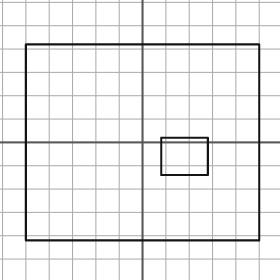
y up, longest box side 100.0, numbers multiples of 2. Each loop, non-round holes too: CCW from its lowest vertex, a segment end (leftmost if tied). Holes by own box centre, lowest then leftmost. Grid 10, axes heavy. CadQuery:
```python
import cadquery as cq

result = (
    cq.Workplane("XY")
    .moveTo(-50.0, -42.0)
    .lineTo(50.0, -42.0)
    .lineTo(50.0, 42.0)
    .lineTo(-50.0, 42.0)
    .close()
    .moveTo(8.0, -14.0)
    .lineTo(28.0, -14.0)
    .lineTo(28.0, 2.0)
    .lineTo(8.0, 2.0)
    .close()
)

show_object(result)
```